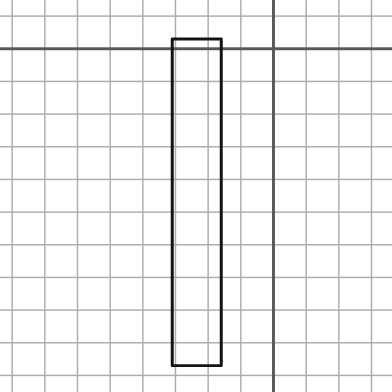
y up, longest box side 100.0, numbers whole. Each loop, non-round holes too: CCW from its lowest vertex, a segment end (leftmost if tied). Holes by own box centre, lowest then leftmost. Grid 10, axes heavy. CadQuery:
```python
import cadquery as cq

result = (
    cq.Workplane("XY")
    .moveTo(-31.0, -97.0)
    .lineTo(-16.0, -97.0)
    .lineTo(-16.0, 3.0)
    .lineTo(-31.0, 3.0)
    .close()
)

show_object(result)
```